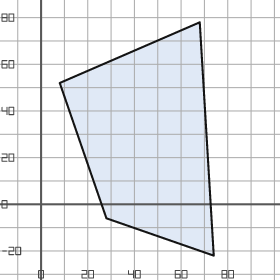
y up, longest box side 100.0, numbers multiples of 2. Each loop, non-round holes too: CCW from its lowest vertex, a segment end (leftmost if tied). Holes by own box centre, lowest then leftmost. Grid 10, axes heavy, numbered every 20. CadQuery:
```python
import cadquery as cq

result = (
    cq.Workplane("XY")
    .moveTo(74.0, -22.0)
    .lineTo(68.0, 78.0)
    .lineTo(8.0, 52.0)
    .lineTo(28.0, -6.0)
    .close()
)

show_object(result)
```